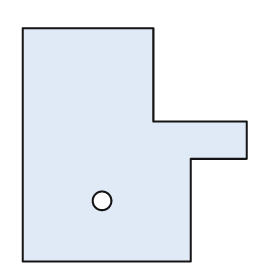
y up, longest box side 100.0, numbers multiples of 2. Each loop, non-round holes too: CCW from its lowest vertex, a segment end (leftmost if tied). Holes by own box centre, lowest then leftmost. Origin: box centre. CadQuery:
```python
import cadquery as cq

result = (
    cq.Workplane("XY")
    .moveTo(-48.0, -50.0)
    .lineTo(24.0, -50.0)
    .lineTo(24.0, -6.0)
    .lineTo(48.0, -6.0)
    .lineTo(48.0, 10.0)
    .lineTo(8.0, 10.0)
    .lineTo(8.0, 50.0)
    .lineTo(-48.0, 50.0)
    .close()
    .moveTo(-14.0, -24.0)
    .circle(4.0)
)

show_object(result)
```